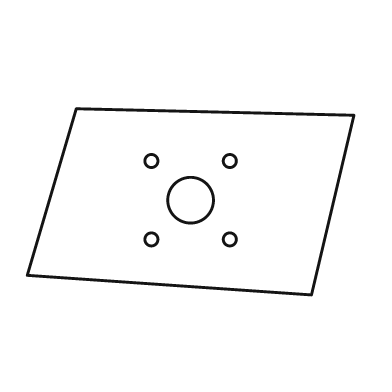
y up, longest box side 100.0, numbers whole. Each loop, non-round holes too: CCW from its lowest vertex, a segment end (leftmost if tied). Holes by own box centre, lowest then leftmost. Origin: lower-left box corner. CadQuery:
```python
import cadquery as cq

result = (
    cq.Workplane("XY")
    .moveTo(87.0, 0.0)
    .lineTo(100.0, 55.0)
    .lineTo(15.0, 57.0)
    .lineTo(0.0, 6.0)
    .close()
    .moveTo(38.0, 17.0)
    .circle(2.0)
    .moveTo(62.0, 17.0)
    .circle(2.0)
    .moveTo(50.0, 29.0)
    .circle(7.0)
    .moveTo(38.0, 41.0)
    .circle(2.0)
    .moveTo(62.0, 41.0)
    .circle(2.0)
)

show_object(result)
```